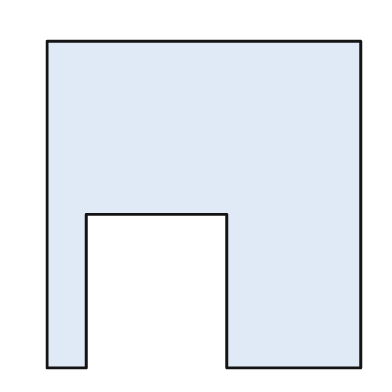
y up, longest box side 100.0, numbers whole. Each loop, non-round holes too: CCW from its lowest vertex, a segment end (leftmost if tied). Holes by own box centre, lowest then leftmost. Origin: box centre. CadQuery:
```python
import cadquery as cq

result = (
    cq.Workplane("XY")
    .moveTo(-48.0, -50.0)
    .lineTo(-36.0, -50.0)
    .lineTo(-36.0, -3.0)
    .lineTo(7.0, -3.0)
    .lineTo(7.0, -50.0)
    .lineTo(48.0, -50.0)
    .lineTo(48.0, 50.0)
    .lineTo(-48.0, 50.0)
    .close()
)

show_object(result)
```